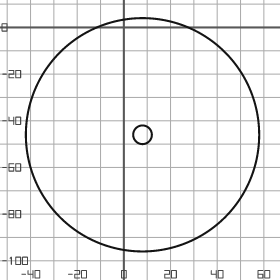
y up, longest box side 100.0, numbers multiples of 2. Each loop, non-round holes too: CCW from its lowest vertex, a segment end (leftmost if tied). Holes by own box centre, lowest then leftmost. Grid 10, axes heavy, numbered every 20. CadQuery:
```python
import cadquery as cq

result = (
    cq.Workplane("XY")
    .moveTo(8.0, -46.0)
    .circle(50.0)
    .moveTo(8.0, -46.0)
    .circle(4.0)
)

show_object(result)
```